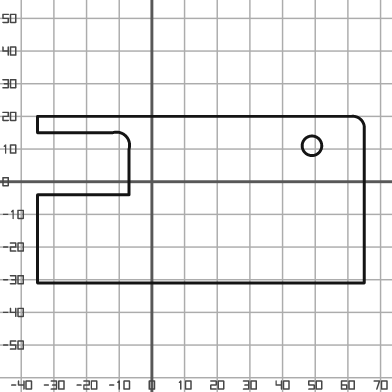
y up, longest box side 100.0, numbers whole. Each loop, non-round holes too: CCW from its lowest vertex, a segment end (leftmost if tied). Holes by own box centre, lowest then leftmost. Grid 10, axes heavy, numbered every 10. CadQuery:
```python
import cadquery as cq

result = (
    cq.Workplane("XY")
    .moveTo(-35.0, -31.0)
    .lineTo(65.0, -31.0)
    .lineTo(65.0, 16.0)
    .threePointArc((64.0, 19.0), (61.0, 20.0))
    .lineTo(-35.0, 20.0)
    .lineTo(-35.0, 15.0)
    .lineTo(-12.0, 15.0)
    .threePointArc((-8.0, 14.0), (-7.0, 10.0))
    .lineTo(-7.0, -4.0)
    .lineTo(-35.0, -4.0)
    .close()
    .moveTo(49.0, 11.0)
    .circle(3.0)
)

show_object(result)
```